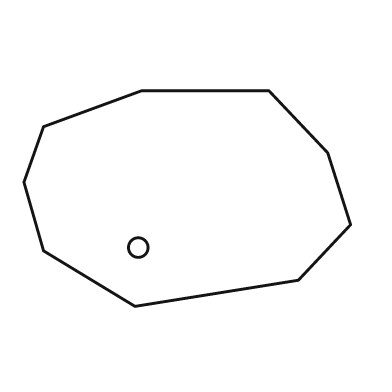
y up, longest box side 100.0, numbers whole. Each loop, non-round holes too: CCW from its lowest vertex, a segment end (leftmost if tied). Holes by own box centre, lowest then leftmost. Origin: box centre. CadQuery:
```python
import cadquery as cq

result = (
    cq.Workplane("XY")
    .moveTo(-16.0, -33.0)
    .lineTo(34.0, -25.0)
    .lineTo(50.0, -8.0)
    .lineTo(43.0, 14.0)
    .lineTo(25.0, 33.0)
    .lineTo(-14.0, 33.0)
    .lineTo(-44.0, 22.0)
    .lineTo(-50.0, 5.0)
    .lineTo(-44.0, -16.0)
    .close()
    .moveTo(-15.0, -15.0)
    .circle(3.0)
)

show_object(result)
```